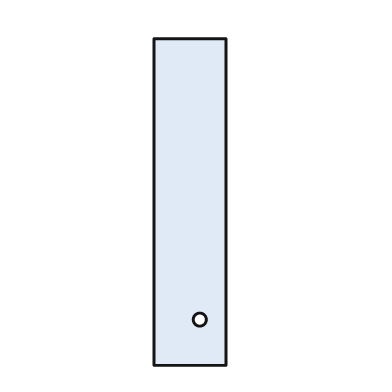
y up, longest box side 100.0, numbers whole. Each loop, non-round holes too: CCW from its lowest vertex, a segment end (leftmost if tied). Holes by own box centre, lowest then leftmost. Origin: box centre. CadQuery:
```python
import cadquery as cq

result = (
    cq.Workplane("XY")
    .moveTo(-11.0, -50.0)
    .lineTo(11.0, -50.0)
    .lineTo(11.0, 50.0)
    .lineTo(-11.0, 50.0)
    .close()
    .moveTo(3.0, -36.0)
    .circle(2.0)
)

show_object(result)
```